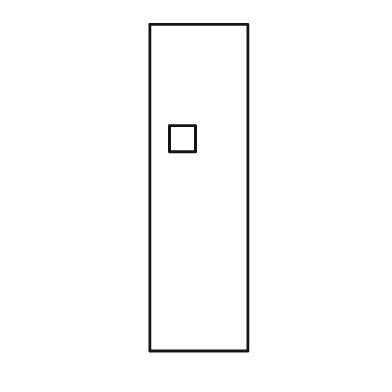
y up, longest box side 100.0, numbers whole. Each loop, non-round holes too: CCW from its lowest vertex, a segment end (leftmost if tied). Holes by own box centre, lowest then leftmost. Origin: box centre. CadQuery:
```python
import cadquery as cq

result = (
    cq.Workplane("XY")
    .moveTo(-15.0, -50.0)
    .lineTo(15.0, -50.0)
    .lineTo(15.0, 50.0)
    .lineTo(-15.0, 50.0)
    .close()
    .moveTo(-9.0, 11.0)
    .lineTo(-1.0, 11.0)
    .lineTo(-1.0, 19.0)
    .lineTo(-9.0, 19.0)
    .close()
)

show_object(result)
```